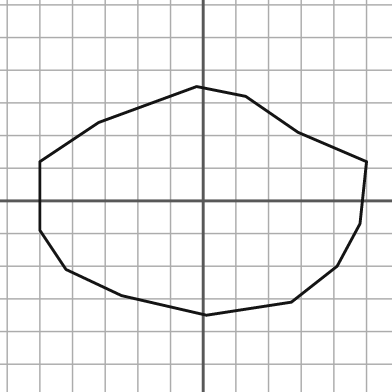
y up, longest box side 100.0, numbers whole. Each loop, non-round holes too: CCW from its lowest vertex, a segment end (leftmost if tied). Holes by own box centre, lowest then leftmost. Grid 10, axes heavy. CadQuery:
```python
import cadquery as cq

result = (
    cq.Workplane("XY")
    .moveTo(1.0, -35.0)
    .lineTo(27.0, -31.0)
    .lineTo(41.0, -20.0)
    .lineTo(48.0, -7.0)
    .lineTo(50.0, 12.0)
    .lineTo(29.0, 21.0)
    .lineTo(13.0, 32.0)
    .lineTo(-2.0, 35.0)
    .lineTo(-32.0, 24.0)
    .lineTo(-50.0, 12.0)
    .lineTo(-50.0, -9.0)
    .lineTo(-42.0, -21.0)
    .lineTo(-25.0, -29.0)
    .close()
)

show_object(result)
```